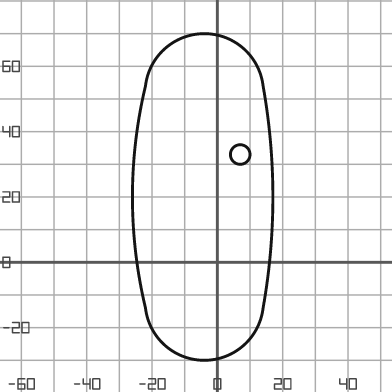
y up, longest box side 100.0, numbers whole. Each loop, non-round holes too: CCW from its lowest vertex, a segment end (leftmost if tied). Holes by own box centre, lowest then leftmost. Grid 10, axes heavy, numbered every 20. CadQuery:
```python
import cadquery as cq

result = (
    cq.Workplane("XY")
    .moveTo(-22.0, -14.0)
    .threePointArc((-4.0, -30.0), (14.0, -14.0))
    .threePointArc((17.0, 20.0), (14.0, 54.0))
    .threePointArc((-4.0, 70.0), (-22.0, 54.0))
    .threePointArc((-26.0, 20.0), (-22.0, -14.0))
    .close()
    .moveTo(7.0, 33.0)
    .circle(3.0)
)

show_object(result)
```